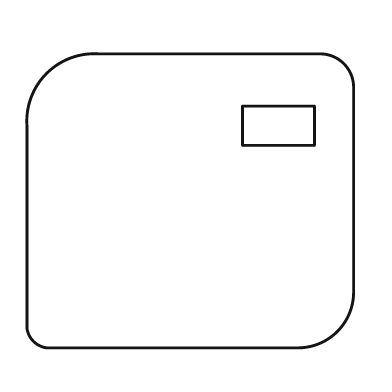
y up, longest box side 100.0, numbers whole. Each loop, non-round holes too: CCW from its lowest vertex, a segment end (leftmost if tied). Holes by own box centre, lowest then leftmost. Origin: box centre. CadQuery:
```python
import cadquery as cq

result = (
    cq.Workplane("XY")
    .moveTo(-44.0, -45.0)
    .lineTo(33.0, -45.0)
    .threePointArc((45.0, -40.0), (50.0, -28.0))
    .lineTo(50.0, 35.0)
    .threePointArc((47.0, 42.0), (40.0, 45.0))
    .lineTo(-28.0, 45.0)
    .threePointArc((-44.0, 39.0), (-50.0, 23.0))
    .lineTo(-50.0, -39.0)
    .threePointArc((-48.0, -43.0), (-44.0, -45.0))
    .close()
    .moveTo(16.0, 17.0)
    .lineTo(38.0, 17.0)
    .lineTo(38.0, 29.0)
    .lineTo(16.0, 29.0)
    .close()
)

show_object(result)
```